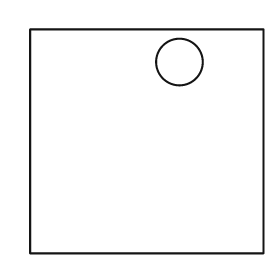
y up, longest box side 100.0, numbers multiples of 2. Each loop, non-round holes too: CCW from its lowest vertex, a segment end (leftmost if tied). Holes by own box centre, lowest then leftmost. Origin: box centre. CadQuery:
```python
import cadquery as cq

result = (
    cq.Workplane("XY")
    .moveTo(-50.0, -48.0)
    .lineTo(50.0, -48.0)
    .lineTo(50.0, 48.0)
    .lineTo(-50.0, 48.0)
    .close()
    .moveTo(14.0, 34.0)
    .circle(10.0)
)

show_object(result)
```